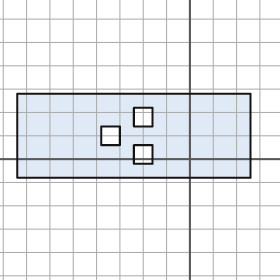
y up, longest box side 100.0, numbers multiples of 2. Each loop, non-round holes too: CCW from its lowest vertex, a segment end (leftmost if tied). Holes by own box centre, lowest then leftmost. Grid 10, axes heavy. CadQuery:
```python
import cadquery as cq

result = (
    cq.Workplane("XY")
    .moveTo(-74.0, -8.0)
    .lineTo(26.0, -8.0)
    .lineTo(26.0, 28.0)
    .lineTo(-74.0, 28.0)
    .close()
    .moveTo(-24.0, -2.0)
    .lineTo(-16.0, -2.0)
    .lineTo(-16.0, 6.0)
    .lineTo(-24.0, 6.0)
    .close()
    .moveTo(-38.0, 6.0)
    .lineTo(-30.0, 6.0)
    .lineTo(-30.0, 14.0)
    .lineTo(-38.0, 14.0)
    .close()
    .moveTo(-24.0, 14.0)
    .lineTo(-16.0, 14.0)
    .lineTo(-16.0, 22.0)
    .lineTo(-24.0, 22.0)
    .close()
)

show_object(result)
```